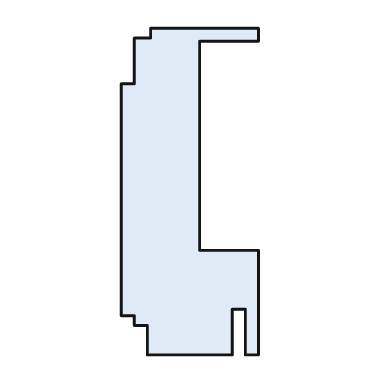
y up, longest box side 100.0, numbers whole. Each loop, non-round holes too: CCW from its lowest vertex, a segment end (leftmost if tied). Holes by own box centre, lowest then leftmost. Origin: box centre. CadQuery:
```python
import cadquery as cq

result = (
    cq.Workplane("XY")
    .moveTo(-13.0, -50.0)
    .lineTo(13.0, -50.0)
    .lineTo(13.0, -36.0)
    .lineTo(17.0, -36.0)
    .lineTo(17.0, -50.0)
    .lineTo(21.0, -50.0)
    .lineTo(21.0, -18.0)
    .lineTo(3.0, -18.0)
    .lineTo(3.0, 46.0)
    .lineTo(21.0, 46.0)
    .lineTo(21.0, 50.0)
    .lineTo(-12.0, 50.0)
    .lineTo(-12.0, 47.0)
    .lineTo(-17.0, 47.0)
    .lineTo(-17.0, 33.0)
    .lineTo(-21.0, 33.0)
    .lineTo(-21.0, -38.0)
    .lineTo(-17.0, -38.0)
    .lineTo(-17.0, -41.0)
    .lineTo(-13.0, -41.0)
    .close()
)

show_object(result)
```